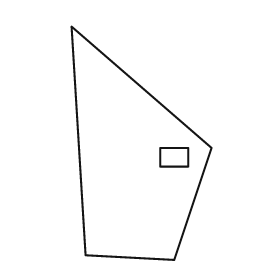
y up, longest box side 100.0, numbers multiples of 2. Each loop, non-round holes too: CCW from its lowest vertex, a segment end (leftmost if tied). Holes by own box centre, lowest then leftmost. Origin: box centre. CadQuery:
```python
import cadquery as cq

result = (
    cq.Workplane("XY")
    .moveTo(14.0, -50.0)
    .lineTo(30.0, -2.0)
    .lineTo(-30.0, 50.0)
    .lineTo(-24.0, -48.0)
    .close()
    .moveTo(8.0, -10.0)
    .lineTo(20.0, -10.0)
    .lineTo(20.0, -2.0)
    .lineTo(8.0, -2.0)
    .close()
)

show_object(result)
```